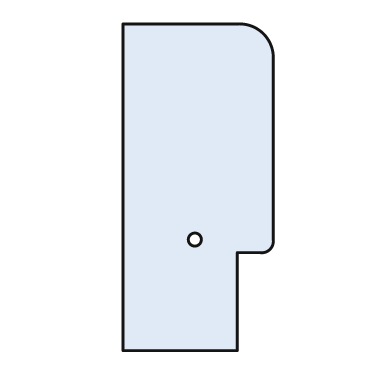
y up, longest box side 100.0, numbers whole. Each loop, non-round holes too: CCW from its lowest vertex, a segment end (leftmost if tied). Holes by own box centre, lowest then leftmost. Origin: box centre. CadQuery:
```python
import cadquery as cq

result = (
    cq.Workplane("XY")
    .moveTo(-23.0, -50.0)
    .lineTo(12.0, -50.0)
    .lineTo(12.0, -20.0)
    .lineTo(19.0, -20.0)
    .threePointArc((22.0, -19.0), (23.0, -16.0))
    .lineTo(23.0, 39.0)
    .threePointArc((20.0, 47.0), (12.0, 50.0))
    .lineTo(-23.0, 50.0)
    .close()
    .moveTo(-1.0, -16.0)
    .circle(2.0)
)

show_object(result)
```